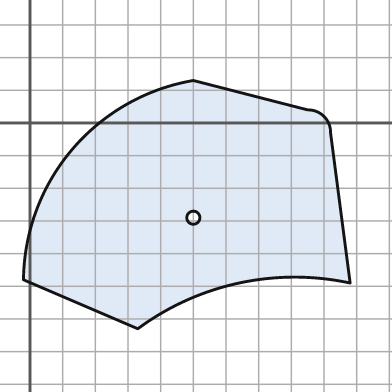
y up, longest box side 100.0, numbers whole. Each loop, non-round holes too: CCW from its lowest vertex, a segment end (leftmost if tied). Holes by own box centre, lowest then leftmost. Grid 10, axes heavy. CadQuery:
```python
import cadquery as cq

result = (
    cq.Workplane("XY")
    .moveTo(33.0, -63.0)
    .threePointArc((64.0, -49.0), (98.0, -49.0))
    .lineTo(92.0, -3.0)
    .threePointArc((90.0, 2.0), (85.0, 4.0))
    .lineTo(50.0, 13.0)
    .threePointArc((13.0, -8.0), (-2.0, -48.0))
    .close()
    .moveTo(50.0, -29.0)
    .circle(2.0)
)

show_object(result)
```